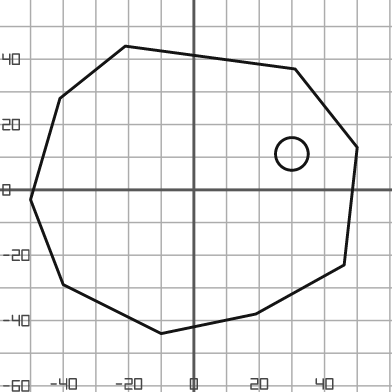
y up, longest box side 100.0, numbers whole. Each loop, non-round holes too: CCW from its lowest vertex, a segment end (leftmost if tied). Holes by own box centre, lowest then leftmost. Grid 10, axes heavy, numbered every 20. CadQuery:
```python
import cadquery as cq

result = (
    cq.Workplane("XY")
    .moveTo(-10.0, -44.0)
    .lineTo(19.0, -38.0)
    .lineTo(46.0, -23.0)
    .lineTo(50.0, 13.0)
    .lineTo(31.0, 37.0)
    .lineTo(-21.0, 44.0)
    .lineTo(-41.0, 28.0)
    .lineTo(-50.0, -3.0)
    .lineTo(-40.0, -29.0)
    .close()
    .moveTo(30.0, 11.0)
    .circle(5.0)
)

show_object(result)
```